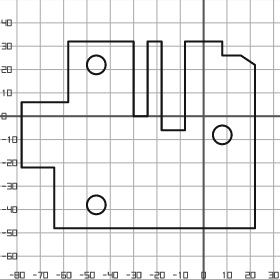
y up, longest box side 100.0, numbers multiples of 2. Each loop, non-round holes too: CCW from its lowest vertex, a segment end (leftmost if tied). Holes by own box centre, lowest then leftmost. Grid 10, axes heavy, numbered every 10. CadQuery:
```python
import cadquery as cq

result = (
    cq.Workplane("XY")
    .moveTo(-64.0, -48.0)
    .lineTo(22.0, -48.0)
    .lineTo(22.0, 22.0)
    .lineTo(16.0, 26.0)
    .lineTo(8.0, 26.0)
    .lineTo(8.0, 32.0)
    .lineTo(-8.0, 32.0)
    .lineTo(-8.0, -6.0)
    .lineTo(-18.0, -6.0)
    .lineTo(-18.0, 32.0)
    .lineTo(-24.0, 32.0)
    .lineTo(-24.0, 0.0)
    .lineTo(-30.0, 0.0)
    .lineTo(-30.0, 32.0)
    .lineTo(-58.0, 32.0)
    .lineTo(-58.0, 6.0)
    .lineTo(-78.0, 6.0)
    .lineTo(-78.0, -22.0)
    .lineTo(-64.0, -22.0)
    .close()
    .moveTo(-46.0, -38.0)
    .circle(4.0)
    .moveTo(8.0, -8.0)
    .circle(4.0)
    .moveTo(-46.0, 22.0)
    .circle(4.0)
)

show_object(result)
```